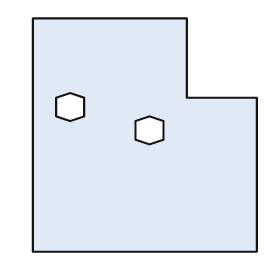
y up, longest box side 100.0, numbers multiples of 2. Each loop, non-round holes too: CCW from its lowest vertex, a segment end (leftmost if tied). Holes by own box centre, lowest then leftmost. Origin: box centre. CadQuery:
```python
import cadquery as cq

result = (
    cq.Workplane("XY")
    .moveTo(-48.0, -50.0)
    .lineTo(48.0, -50.0)
    .lineTo(48.0, 16.0)
    .lineTo(18.0, 16.0)
    .lineTo(18.0, 50.0)
    .lineTo(-48.0, 50.0)
    .close()
    .moveTo(2.0, -4.0)
    .lineTo(8.0, -2.0)
    .lineTo(8.0, 6.0)
    .lineTo(2.0, 8.0)
    .lineTo(-4.0, 6.0)
    .lineTo(-4.0, -2.0)
    .close()
    .moveTo(-32.0, 6.0)
    .lineTo(-26.0, 8.0)
    .lineTo(-26.0, 16.0)
    .lineTo(-32.0, 18.0)
    .lineTo(-38.0, 16.0)
    .lineTo(-38.0, 8.0)
    .close()
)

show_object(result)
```